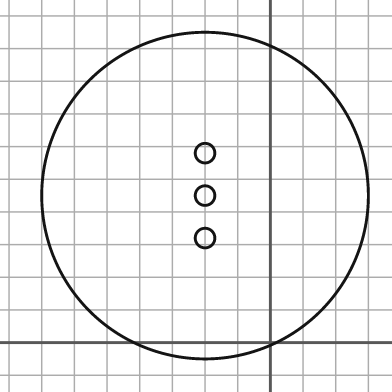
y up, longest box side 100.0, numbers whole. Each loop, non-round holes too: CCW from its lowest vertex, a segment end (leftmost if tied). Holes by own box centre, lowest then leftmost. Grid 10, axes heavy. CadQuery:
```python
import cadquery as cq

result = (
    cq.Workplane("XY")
    .moveTo(-20.0, 45.0)
    .circle(50.0)
    .moveTo(-20.0, 32.0)
    .circle(3.0)
    .moveTo(-20.0, 45.0)
    .circle(3.0)
    .moveTo(-20.0, 58.0)
    .circle(3.0)
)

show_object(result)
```